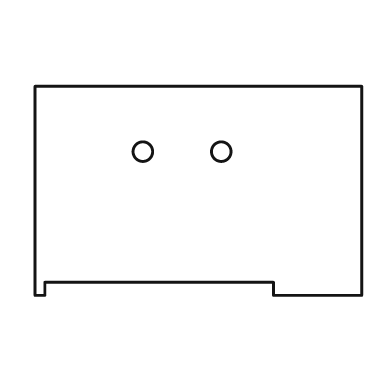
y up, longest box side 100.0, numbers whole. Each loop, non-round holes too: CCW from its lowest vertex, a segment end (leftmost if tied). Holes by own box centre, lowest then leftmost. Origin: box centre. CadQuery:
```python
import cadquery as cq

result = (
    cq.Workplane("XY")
    .moveTo(-50.0, -32.0)
    .lineTo(-47.0, -32.0)
    .lineTo(-47.0, -28.0)
    .lineTo(23.0, -28.0)
    .lineTo(23.0, -32.0)
    .lineTo(50.0, -32.0)
    .lineTo(50.0, 32.0)
    .lineTo(-50.0, 32.0)
    .close()
    .moveTo(-17.0, 12.0)
    .circle(3.0)
    .moveTo(7.0, 12.0)
    .circle(3.0)
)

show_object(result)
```